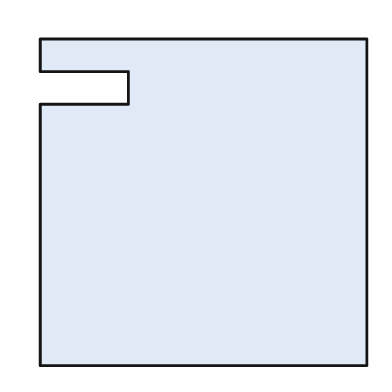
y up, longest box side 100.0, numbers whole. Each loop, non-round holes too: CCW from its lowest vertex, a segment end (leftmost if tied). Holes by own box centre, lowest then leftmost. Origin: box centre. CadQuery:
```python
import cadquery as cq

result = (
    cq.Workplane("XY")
    .moveTo(-50.0, -50.0)
    .lineTo(50.0, -50.0)
    .lineTo(50.0, 50.0)
    .lineTo(-50.0, 50.0)
    .lineTo(-50.0, 40.0)
    .lineTo(-23.0, 40.0)
    .lineTo(-23.0, 30.0)
    .lineTo(-50.0, 30.0)
    .close()
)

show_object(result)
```